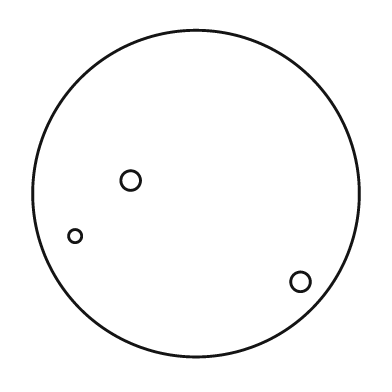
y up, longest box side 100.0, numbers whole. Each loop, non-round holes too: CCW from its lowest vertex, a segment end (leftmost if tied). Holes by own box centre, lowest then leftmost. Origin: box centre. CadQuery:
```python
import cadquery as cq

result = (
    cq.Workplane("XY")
    .moveTo(0.0, 0.0)
    .circle(50.0)
    .moveTo(32.0, -27.0)
    .circle(3.0)
    .moveTo(-37.0, -13.0)
    .circle(2.0)
    .moveTo(-20.0, 4.0)
    .circle(3.0)
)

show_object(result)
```